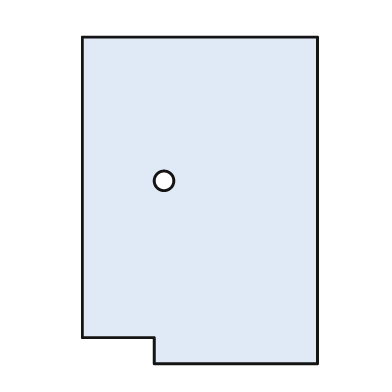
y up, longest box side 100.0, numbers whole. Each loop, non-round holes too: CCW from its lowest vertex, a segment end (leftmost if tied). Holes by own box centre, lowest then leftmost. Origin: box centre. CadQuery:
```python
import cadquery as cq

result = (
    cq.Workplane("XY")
    .moveTo(-14.0, -50.0)
    .lineTo(36.0, -50.0)
    .lineTo(36.0, 50.0)
    .lineTo(-36.0, 50.0)
    .lineTo(-36.0, -42.0)
    .lineTo(-14.0, -42.0)
    .close()
    .moveTo(-11.0, 6.0)
    .circle(3.0)
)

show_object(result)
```